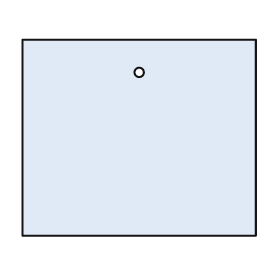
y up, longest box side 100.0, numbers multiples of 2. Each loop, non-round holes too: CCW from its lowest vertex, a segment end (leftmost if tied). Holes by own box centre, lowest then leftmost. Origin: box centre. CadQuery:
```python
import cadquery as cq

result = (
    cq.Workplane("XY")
    .moveTo(-50.0, -42.0)
    .lineTo(50.0, -42.0)
    .lineTo(50.0, 42.0)
    .lineTo(-50.0, 42.0)
    .close()
    .moveTo(0.0, 28.0)
    .circle(2.0)
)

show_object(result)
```